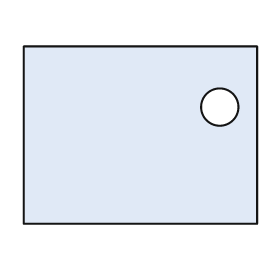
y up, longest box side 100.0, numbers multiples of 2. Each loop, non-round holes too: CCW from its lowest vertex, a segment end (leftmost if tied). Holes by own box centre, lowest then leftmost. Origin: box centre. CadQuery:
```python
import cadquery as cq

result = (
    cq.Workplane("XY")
    .moveTo(-50.0, -38.0)
    .lineTo(50.0, -38.0)
    .lineTo(50.0, 38.0)
    .lineTo(-50.0, 38.0)
    .close()
    .moveTo(34.0, 12.0)
    .circle(8.0)
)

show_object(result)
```